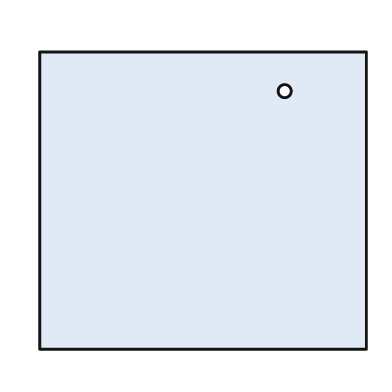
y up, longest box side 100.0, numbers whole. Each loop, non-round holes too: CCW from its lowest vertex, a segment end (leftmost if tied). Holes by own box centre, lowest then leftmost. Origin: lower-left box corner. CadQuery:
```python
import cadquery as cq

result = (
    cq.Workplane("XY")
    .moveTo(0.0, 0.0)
    .lineTo(100.0, 0.0)
    .lineTo(100.0, 91.0)
    .lineTo(0.0, 91.0)
    .close()
    .moveTo(75.0, 79.0)
    .circle(2.0)
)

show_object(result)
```